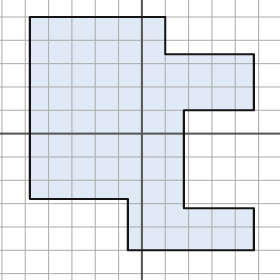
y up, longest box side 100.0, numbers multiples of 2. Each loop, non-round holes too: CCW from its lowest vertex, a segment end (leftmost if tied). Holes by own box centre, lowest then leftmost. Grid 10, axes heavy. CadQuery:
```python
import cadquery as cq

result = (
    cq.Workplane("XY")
    .moveTo(-6.0, -50.0)
    .lineTo(48.0, -50.0)
    .lineTo(48.0, -32.0)
    .lineTo(18.0, -32.0)
    .lineTo(18.0, 10.0)
    .lineTo(48.0, 10.0)
    .lineTo(48.0, 34.0)
    .lineTo(10.0, 34.0)
    .lineTo(10.0, 50.0)
    .lineTo(-48.0, 50.0)
    .lineTo(-48.0, -28.0)
    .lineTo(-6.0, -28.0)
    .close()
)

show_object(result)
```